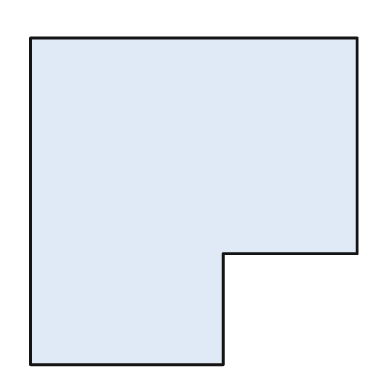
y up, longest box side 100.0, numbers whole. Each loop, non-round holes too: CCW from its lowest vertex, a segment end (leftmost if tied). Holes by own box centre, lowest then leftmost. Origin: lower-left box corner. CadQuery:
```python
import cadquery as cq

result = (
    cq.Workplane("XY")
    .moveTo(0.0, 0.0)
    .lineTo(59.0, 0.0)
    .lineTo(59.0, 34.0)
    .lineTo(100.0, 34.0)
    .lineTo(100.0, 100.0)
    .lineTo(0.0, 100.0)
    .close()
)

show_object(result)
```